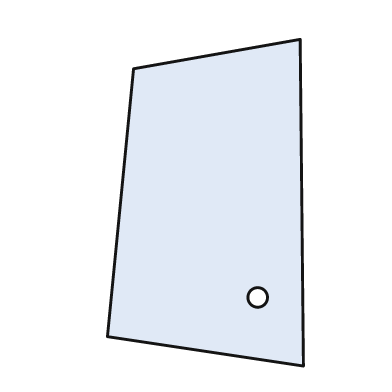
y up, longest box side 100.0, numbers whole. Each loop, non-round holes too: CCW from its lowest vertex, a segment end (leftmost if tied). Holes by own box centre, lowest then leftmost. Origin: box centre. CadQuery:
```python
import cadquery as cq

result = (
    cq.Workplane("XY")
    .moveTo(30.0, -50.0)
    .lineTo(29.0, 50.0)
    .lineTo(-22.0, 41.0)
    .lineTo(-30.0, -41.0)
    .close()
    .moveTo(16.0, -29.0)
    .circle(3.0)
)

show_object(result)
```